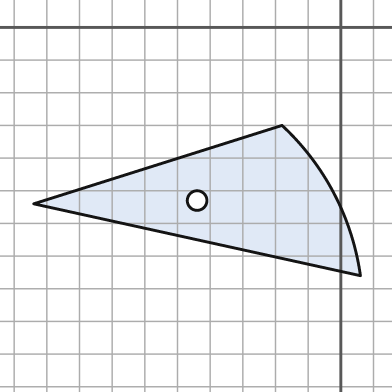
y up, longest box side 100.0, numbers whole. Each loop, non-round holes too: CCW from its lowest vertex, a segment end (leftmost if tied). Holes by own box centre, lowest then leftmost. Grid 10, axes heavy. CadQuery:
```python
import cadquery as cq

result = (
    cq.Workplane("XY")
    .moveTo(6.0, -76.0)
    .threePointArc((-2.0, -51.0), (-18.0, -30.0))
    .lineTo(-94.0, -54.0)
    .close()
    .moveTo(-44.0, -53.0)
    .circle(3.0)
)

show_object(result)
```